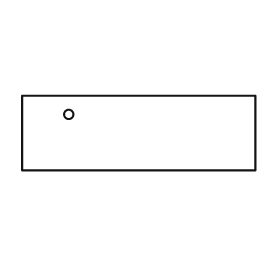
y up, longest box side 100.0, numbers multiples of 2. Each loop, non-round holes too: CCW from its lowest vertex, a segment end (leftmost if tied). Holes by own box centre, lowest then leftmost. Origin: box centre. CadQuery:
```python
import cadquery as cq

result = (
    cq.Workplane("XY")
    .moveTo(-50.0, -16.0)
    .lineTo(50.0, -16.0)
    .lineTo(50.0, 16.0)
    .lineTo(-50.0, 16.0)
    .close()
    .moveTo(-30.0, 8.0)
    .circle(2.0)
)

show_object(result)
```